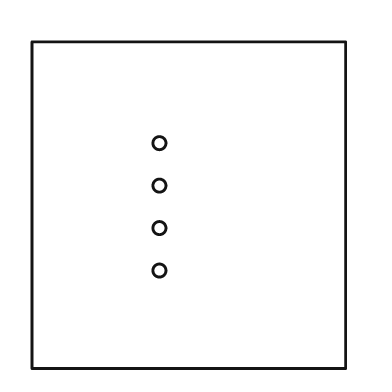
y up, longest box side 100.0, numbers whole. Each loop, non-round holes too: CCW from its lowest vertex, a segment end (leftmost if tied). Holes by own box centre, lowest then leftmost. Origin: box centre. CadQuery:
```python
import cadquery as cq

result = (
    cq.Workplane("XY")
    .moveTo(-48.0, -50.0)
    .lineTo(48.0, -50.0)
    .lineTo(48.0, 50.0)
    .lineTo(-48.0, 50.0)
    .close()
    .moveTo(-9.0, -20.0)
    .circle(2.0)
    .moveTo(-9.0, -7.0)
    .circle(2.0)
    .moveTo(-9.0, 6.0)
    .circle(2.0)
    .moveTo(-9.0, 19.0)
    .circle(2.0)
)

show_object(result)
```